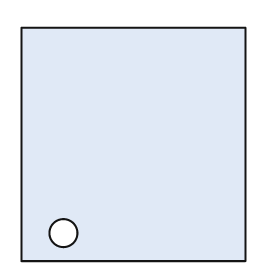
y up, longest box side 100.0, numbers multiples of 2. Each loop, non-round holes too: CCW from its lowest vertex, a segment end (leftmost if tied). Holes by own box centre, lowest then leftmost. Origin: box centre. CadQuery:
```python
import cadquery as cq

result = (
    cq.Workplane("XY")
    .moveTo(-48.0, -50.0)
    .lineTo(48.0, -50.0)
    .lineTo(48.0, 50.0)
    .lineTo(-48.0, 50.0)
    .close()
    .moveTo(-30.0, -38.0)
    .circle(6.0)
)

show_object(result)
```